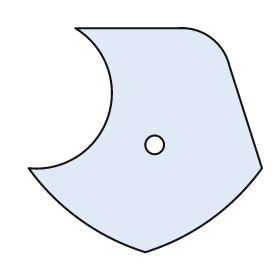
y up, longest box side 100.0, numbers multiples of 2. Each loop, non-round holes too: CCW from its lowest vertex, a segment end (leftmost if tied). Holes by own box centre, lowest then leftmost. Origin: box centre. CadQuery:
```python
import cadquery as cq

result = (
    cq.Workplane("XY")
    .moveTo(0.0, -48.0)
    .threePointArc((28.0, -34.0), (50.0, -12.0))
    .lineTo(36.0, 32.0)
    .threePointArc((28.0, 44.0), (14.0, 48.0))
    .lineTo(-30.0, 48.0)
    .threePointArc((-16.0, 10.0), (-50.0, -12.0))
    .threePointArc((-28.0, -34.0), (0.0, -48.0))
    .close()
    .moveTo(4.0, -2.0)
    .circle(4.0)
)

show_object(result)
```